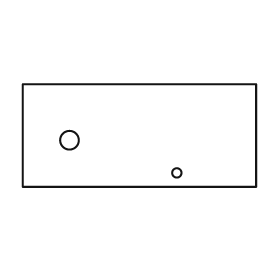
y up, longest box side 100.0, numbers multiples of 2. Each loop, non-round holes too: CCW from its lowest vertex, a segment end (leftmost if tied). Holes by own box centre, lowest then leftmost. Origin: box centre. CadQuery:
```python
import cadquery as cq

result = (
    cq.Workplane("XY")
    .moveTo(-50.0, -22.0)
    .lineTo(50.0, -22.0)
    .lineTo(50.0, 22.0)
    .lineTo(-50.0, 22.0)
    .close()
    .moveTo(16.0, -16.0)
    .circle(2.0)
    .moveTo(-30.0, -2.0)
    .circle(4.0)
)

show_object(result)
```